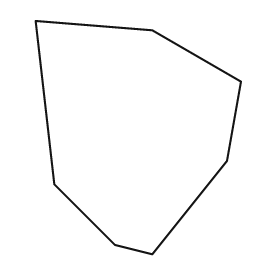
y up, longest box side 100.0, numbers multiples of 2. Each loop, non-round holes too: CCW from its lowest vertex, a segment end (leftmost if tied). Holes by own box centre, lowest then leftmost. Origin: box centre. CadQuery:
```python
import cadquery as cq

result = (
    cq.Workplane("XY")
    .moveTo(6.0, -50.0)
    .lineTo(38.0, -10.0)
    .lineTo(44.0, 24.0)
    .lineTo(6.0, 46.0)
    .lineTo(-44.0, 50.0)
    .lineTo(-36.0, -20.0)
    .lineTo(-10.0, -46.0)
    .close()
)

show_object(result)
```